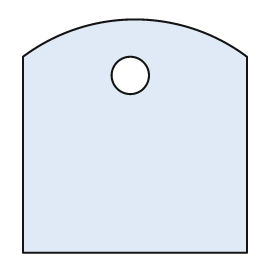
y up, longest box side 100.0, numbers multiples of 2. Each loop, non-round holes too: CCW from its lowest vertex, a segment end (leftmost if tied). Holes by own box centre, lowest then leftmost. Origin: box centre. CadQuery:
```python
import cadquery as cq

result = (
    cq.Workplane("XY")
    .moveTo(-48.0, -50.0)
    .lineTo(48.0, -50.0)
    .lineTo(48.0, 34.0)
    .threePointArc((0.0, 50.0), (-48.0, 34.0))
    .close()
    .moveTo(-2.0, 26.0)
    .circle(8.0)
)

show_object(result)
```